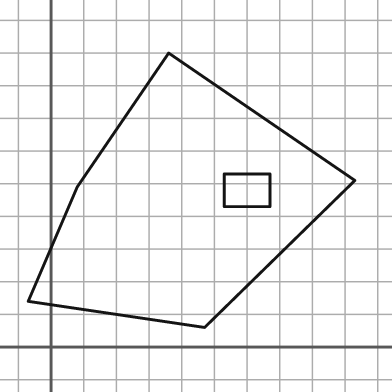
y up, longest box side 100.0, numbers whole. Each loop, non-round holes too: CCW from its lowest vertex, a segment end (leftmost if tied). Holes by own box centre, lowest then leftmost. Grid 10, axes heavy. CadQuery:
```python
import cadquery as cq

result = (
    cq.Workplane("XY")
    .moveTo(47.0, 6.0)
    .lineTo(93.0, 51.0)
    .lineTo(36.0, 90.0)
    .lineTo(8.0, 49.0)
    .lineTo(-7.0, 14.0)
    .close()
    .moveTo(53.0, 43.0)
    .lineTo(67.0, 43.0)
    .lineTo(67.0, 53.0)
    .lineTo(53.0, 53.0)
    .close()
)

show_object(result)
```